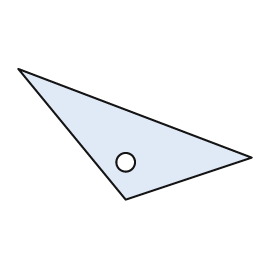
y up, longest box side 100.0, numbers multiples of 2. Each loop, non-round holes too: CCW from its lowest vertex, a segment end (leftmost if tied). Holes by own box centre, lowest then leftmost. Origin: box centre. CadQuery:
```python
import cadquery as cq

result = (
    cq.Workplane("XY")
    .moveTo(-4.0, -28.0)
    .lineTo(50.0, -10.0)
    .lineTo(-50.0, 28.0)
    .close()
    .moveTo(-4.0, -12.0)
    .circle(4.0)
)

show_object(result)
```